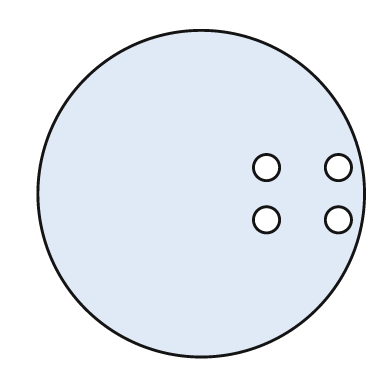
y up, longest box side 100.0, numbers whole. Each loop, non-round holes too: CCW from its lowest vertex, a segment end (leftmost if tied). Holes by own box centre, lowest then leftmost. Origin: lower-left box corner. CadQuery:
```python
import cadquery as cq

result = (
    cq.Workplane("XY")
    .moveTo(50.0, 50.0)
    .circle(50.0)
    .moveTo(70.0, 42.0)
    .circle(4.0)
    .moveTo(92.0, 42.0)
    .circle(4.0)
    .moveTo(70.0, 58.0)
    .circle(4.0)
    .moveTo(92.0, 58.0)
    .circle(4.0)
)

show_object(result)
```